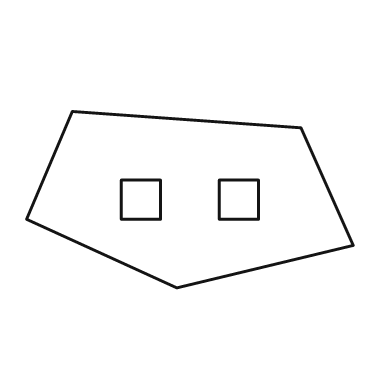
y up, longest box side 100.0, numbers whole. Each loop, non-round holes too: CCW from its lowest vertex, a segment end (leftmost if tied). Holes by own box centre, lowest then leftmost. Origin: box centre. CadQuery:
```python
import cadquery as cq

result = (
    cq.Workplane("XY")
    .moveTo(-4.0, -27.0)
    .lineTo(50.0, -14.0)
    .lineTo(34.0, 22.0)
    .lineTo(-36.0, 27.0)
    .lineTo(-50.0, -6.0)
    .close()
    .moveTo(-21.0, -6.0)
    .lineTo(-9.0, -6.0)
    .lineTo(-9.0, 6.0)
    .lineTo(-21.0, 6.0)
    .close()
    .moveTo(9.0, -6.0)
    .lineTo(21.0, -6.0)
    .lineTo(21.0, 6.0)
    .lineTo(9.0, 6.0)
    .close()
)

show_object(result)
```